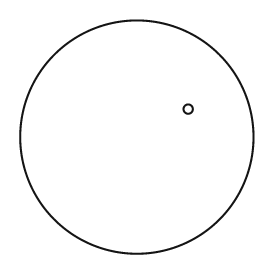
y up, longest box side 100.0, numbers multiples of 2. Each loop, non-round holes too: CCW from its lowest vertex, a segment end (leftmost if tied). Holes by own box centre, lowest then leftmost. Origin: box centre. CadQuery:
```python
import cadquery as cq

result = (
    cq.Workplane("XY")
    .moveTo(0.0, 0.0)
    .circle(50.0)
    .moveTo(22.0, 12.0)
    .circle(2.0)
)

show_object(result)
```